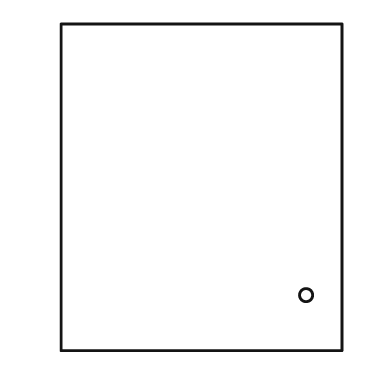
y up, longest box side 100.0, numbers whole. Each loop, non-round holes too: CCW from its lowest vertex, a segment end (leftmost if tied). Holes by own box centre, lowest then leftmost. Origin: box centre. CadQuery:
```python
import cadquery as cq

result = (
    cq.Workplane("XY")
    .moveTo(-43.0, -50.0)
    .lineTo(43.0, -50.0)
    .lineTo(43.0, 50.0)
    .lineTo(-43.0, 50.0)
    .close()
    .moveTo(32.0, -33.0)
    .circle(2.0)
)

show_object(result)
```